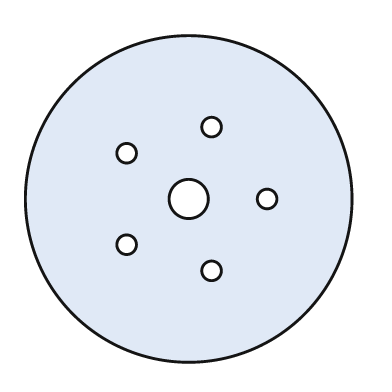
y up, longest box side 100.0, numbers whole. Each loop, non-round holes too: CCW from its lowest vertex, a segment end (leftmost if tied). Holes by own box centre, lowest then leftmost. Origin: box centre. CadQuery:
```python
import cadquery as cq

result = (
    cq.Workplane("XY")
    .moveTo(0.0, 0.0)
    .circle(50.0)
    .moveTo(7.0, -22.0)
    .circle(3.0)
    .moveTo(-19.0, -14.0)
    .circle(3.0)
    .moveTo(0.0, 0.0)
    .circle(6.0)
    .moveTo(24.0, 0.0)
    .circle(3.0)
    .moveTo(-19.0, 14.0)
    .circle(3.0)
    .moveTo(7.0, 22.0)
    .circle(3.0)
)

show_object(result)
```